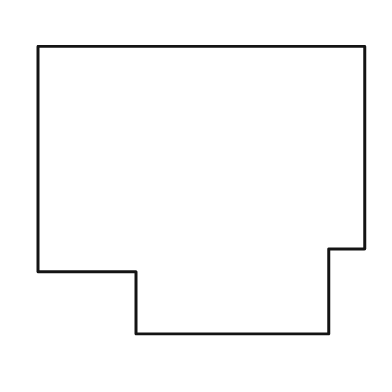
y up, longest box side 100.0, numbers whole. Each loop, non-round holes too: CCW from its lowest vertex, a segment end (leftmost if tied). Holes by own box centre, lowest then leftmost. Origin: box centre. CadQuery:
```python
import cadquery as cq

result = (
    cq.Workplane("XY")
    .moveTo(-20.0, -44.0)
    .lineTo(39.0, -44.0)
    .lineTo(39.0, -18.0)
    .lineTo(50.0, -18.0)
    .lineTo(50.0, 44.0)
    .lineTo(-50.0, 44.0)
    .lineTo(-50.0, -25.0)
    .lineTo(-20.0, -25.0)
    .close()
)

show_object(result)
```